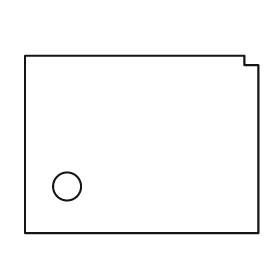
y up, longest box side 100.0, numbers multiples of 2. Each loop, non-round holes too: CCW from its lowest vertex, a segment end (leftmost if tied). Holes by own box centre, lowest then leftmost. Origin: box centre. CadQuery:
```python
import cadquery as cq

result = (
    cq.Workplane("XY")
    .moveTo(-50.0, -38.0)
    .lineTo(50.0, -38.0)
    .lineTo(50.0, 34.0)
    .lineTo(44.0, 34.0)
    .lineTo(44.0, 38.0)
    .lineTo(-50.0, 38.0)
    .close()
    .moveTo(-32.0, -18.0)
    .circle(6.0)
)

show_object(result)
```